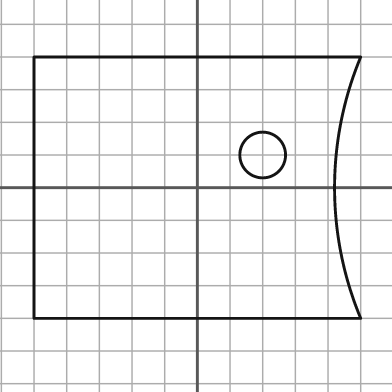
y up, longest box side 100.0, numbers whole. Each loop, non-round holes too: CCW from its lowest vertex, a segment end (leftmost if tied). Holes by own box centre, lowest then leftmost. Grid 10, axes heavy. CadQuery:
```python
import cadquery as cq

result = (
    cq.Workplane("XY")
    .moveTo(-50.0, -40.0)
    .lineTo(50.0, -40.0)
    .threePointArc((42.0, 0.0), (50.0, 40.0))
    .lineTo(-50.0, 40.0)
    .close()
    .moveTo(20.0, 10.0)
    .circle(7.0)
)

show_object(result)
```